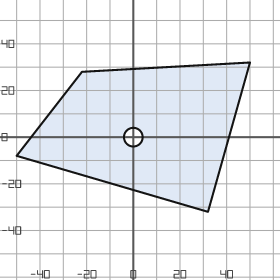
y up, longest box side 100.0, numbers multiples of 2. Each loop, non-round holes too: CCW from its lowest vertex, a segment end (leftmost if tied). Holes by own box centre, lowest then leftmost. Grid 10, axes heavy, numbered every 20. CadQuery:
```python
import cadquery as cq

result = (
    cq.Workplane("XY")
    .moveTo(32.0, -32.0)
    .lineTo(50.0, 32.0)
    .lineTo(-22.0, 28.0)
    .lineTo(-50.0, -8.0)
    .close()
    .moveTo(0.0, 0.0)
    .circle(4.0)
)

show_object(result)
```